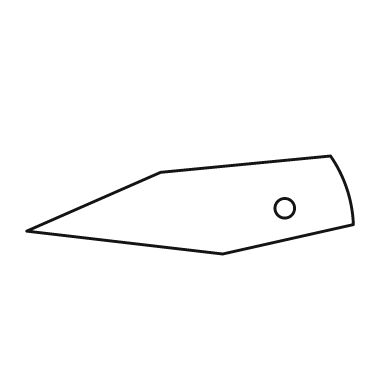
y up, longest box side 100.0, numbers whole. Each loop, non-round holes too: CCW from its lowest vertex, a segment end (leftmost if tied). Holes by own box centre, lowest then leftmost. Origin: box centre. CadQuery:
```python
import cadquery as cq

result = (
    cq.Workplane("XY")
    .moveTo(10.0, -15.0)
    .lineTo(50.0, -6.0)
    .threePointArc((48.0, 5.0), (43.0, 15.0))
    .lineTo(-9.0, 10.0)
    .lineTo(-50.0, -8.0)
    .close()
    .moveTo(29.0, -1.0)
    .circle(3.0)
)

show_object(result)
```